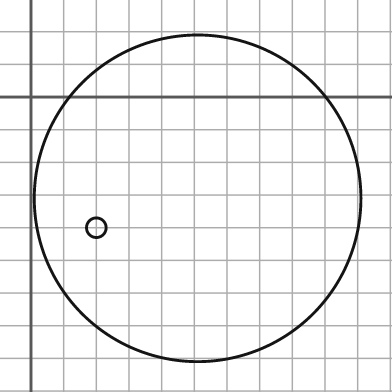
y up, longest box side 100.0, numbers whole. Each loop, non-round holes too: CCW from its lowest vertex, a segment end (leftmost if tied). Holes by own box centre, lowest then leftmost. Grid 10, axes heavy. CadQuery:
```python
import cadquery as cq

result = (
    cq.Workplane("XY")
    .moveTo(51.0, -31.0)
    .circle(50.0)
    .moveTo(20.0, -40.0)
    .circle(3.0)
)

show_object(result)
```